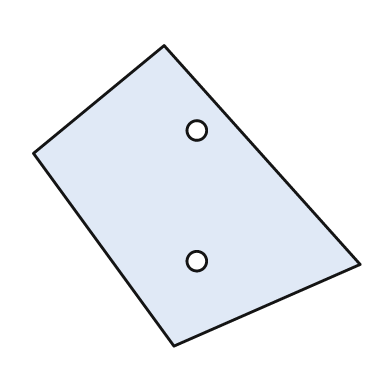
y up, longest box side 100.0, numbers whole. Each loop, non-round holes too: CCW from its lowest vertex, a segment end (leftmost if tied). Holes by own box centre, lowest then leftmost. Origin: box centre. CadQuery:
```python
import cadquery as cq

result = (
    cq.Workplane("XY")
    .moveTo(-7.0, -46.0)
    .lineTo(50.0, -21.0)
    .lineTo(-10.0, 46.0)
    .lineTo(-50.0, 13.0)
    .close()
    .moveTo(0.0, -20.0)
    .circle(3.0)
    .moveTo(0.0, 20.0)
    .circle(3.0)
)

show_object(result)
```